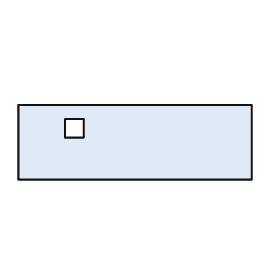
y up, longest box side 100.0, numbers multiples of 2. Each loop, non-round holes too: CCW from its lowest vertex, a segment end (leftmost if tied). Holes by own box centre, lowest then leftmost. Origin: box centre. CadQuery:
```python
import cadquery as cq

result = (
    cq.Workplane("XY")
    .moveTo(-50.0, -16.0)
    .lineTo(50.0, -16.0)
    .lineTo(50.0, 16.0)
    .lineTo(-50.0, 16.0)
    .close()
    .moveTo(-30.0, 2.0)
    .lineTo(-22.0, 2.0)
    .lineTo(-22.0, 10.0)
    .lineTo(-30.0, 10.0)
    .close()
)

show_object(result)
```